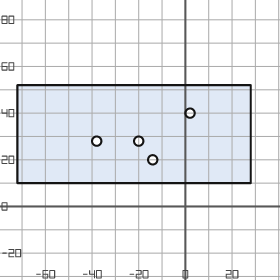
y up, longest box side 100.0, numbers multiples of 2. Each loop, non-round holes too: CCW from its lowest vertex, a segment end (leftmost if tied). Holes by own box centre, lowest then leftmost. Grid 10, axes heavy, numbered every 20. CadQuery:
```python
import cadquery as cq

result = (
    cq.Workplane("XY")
    .moveTo(-72.0, 10.0)
    .lineTo(28.0, 10.0)
    .lineTo(28.0, 52.0)
    .lineTo(-72.0, 52.0)
    .close()
    .moveTo(-14.0, 20.0)
    .circle(2.0)
    .moveTo(-38.0, 28.0)
    .circle(2.0)
    .moveTo(-20.0, 28.0)
    .circle(2.0)
    .moveTo(2.0, 40.0)
    .circle(2.0)
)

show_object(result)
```